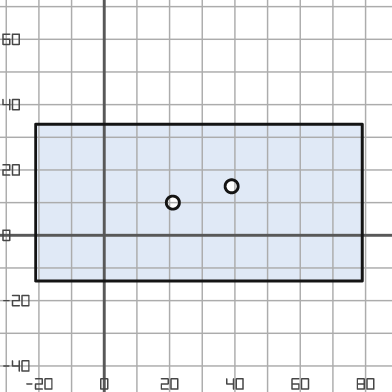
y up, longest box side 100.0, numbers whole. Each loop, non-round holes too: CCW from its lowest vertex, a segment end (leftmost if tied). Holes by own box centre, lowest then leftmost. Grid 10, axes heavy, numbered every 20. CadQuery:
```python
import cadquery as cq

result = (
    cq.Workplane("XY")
    .moveTo(-21.0, -14.0)
    .lineTo(79.0, -14.0)
    .lineTo(79.0, 34.0)
    .lineTo(-21.0, 34.0)
    .close()
    .moveTo(21.0, 10.0)
    .circle(2.0)
    .moveTo(39.0, 15.0)
    .circle(2.0)
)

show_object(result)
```